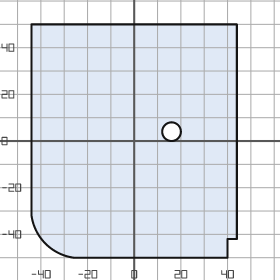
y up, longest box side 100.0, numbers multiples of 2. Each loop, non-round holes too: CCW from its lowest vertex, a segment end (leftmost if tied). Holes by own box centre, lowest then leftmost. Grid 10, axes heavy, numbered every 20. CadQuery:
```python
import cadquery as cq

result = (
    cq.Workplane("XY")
    .moveTo(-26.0, -50.0)
    .lineTo(40.0, -50.0)
    .lineTo(40.0, -42.0)
    .lineTo(44.0, -42.0)
    .lineTo(44.0, 50.0)
    .lineTo(-44.0, 50.0)
    .lineTo(-44.0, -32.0)
    .threePointArc((-38.0, -44.0), (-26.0, -50.0))
    .close()
    .moveTo(16.0, 4.0)
    .circle(4.0)
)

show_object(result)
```